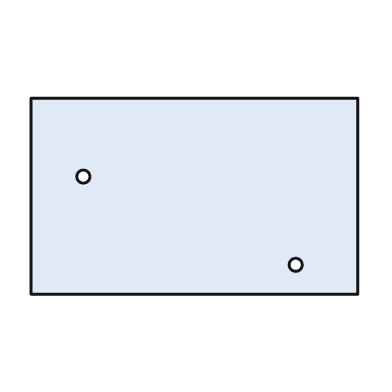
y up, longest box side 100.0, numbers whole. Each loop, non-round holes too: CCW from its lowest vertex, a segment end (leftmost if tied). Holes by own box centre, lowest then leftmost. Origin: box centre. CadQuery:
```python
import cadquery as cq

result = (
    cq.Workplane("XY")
    .moveTo(-50.0, -30.0)
    .lineTo(50.0, -30.0)
    .lineTo(50.0, 30.0)
    .lineTo(-50.0, 30.0)
    .close()
    .moveTo(31.0, -21.0)
    .circle(2.0)
    .moveTo(-34.0, 6.0)
    .circle(2.0)
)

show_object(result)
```